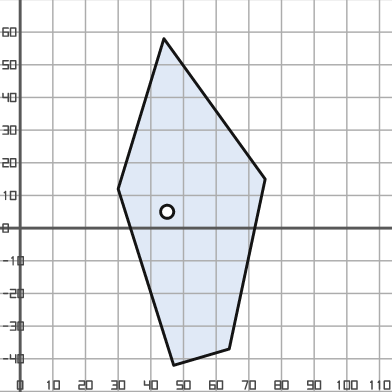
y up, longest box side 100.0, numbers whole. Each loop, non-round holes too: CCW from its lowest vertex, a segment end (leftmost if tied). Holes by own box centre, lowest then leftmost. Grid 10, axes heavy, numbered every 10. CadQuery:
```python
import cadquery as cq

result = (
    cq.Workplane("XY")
    .moveTo(47.0, -42.0)
    .lineTo(64.0, -37.0)
    .lineTo(75.0, 15.0)
    .lineTo(44.0, 58.0)
    .lineTo(30.0, 12.0)
    .close()
    .moveTo(45.0, 5.0)
    .circle(2.0)
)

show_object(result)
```